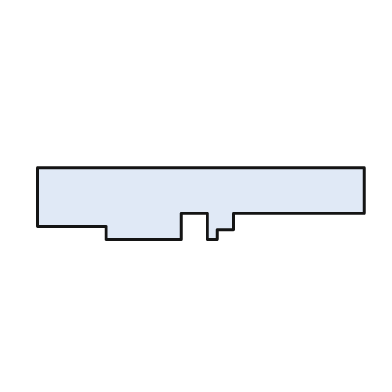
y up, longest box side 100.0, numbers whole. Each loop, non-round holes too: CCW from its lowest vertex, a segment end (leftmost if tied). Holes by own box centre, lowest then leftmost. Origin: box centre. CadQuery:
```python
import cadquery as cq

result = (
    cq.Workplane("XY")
    .moveTo(-29.0, -11.0)
    .lineTo(-6.0, -11.0)
    .lineTo(-6.0, -3.0)
    .lineTo(2.0, -3.0)
    .lineTo(2.0, -11.0)
    .lineTo(5.0, -11.0)
    .lineTo(5.0, -8.0)
    .lineTo(10.0, -8.0)
    .lineTo(10.0, -3.0)
    .lineTo(50.0, -3.0)
    .lineTo(50.0, 11.0)
    .lineTo(-50.0, 11.0)
    .lineTo(-50.0, -7.0)
    .lineTo(-29.0, -7.0)
    .close()
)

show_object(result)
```